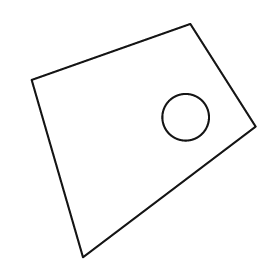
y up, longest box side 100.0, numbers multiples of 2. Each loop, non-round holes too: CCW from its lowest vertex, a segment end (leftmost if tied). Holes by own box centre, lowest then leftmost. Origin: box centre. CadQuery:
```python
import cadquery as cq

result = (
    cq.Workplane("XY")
    .moveTo(-26.0, -50.0)
    .lineTo(48.0, 6.0)
    .lineTo(20.0, 50.0)
    .lineTo(-48.0, 26.0)
    .close()
    .moveTo(18.0, 10.0)
    .circle(10.0)
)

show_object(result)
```